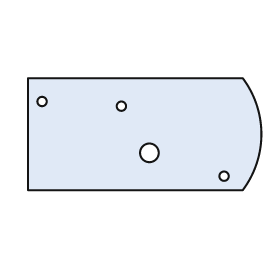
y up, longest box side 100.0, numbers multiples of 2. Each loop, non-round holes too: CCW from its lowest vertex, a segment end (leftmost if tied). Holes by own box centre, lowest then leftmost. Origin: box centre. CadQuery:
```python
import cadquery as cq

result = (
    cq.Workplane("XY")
    .moveTo(-50.0, -24.0)
    .lineTo(42.0, -24.0)
    .threePointArc((50.0, 0.0), (42.0, 24.0))
    .lineTo(-50.0, 24.0)
    .close()
    .moveTo(34.0, -18.0)
    .circle(2.0)
    .moveTo(2.0, -8.0)
    .circle(4.0)
    .moveTo(-10.0, 12.0)
    .circle(2.0)
    .moveTo(-44.0, 14.0)
    .circle(2.0)
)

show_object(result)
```